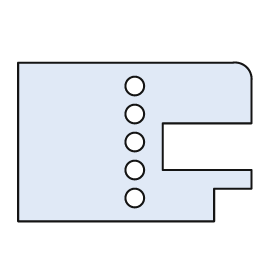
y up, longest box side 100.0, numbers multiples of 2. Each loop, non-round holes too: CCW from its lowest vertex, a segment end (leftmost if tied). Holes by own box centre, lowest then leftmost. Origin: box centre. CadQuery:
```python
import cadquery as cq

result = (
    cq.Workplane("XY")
    .moveTo(-50.0, -34.0)
    .lineTo(34.0, -34.0)
    .lineTo(34.0, -20.0)
    .lineTo(50.0, -20.0)
    .lineTo(50.0, -12.0)
    .lineTo(12.0, -12.0)
    .lineTo(12.0, 8.0)
    .lineTo(50.0, 8.0)
    .lineTo(50.0, 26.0)
    .threePointArc((48.0, 32.0), (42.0, 34.0))
    .lineTo(-50.0, 34.0)
    .close()
    .moveTo(0.0, -24.0)
    .circle(4.0)
    .moveTo(0.0, -12.0)
    .circle(4.0)
    .moveTo(0.0, 0.0)
    .circle(4.0)
    .moveTo(0.0, 12.0)
    .circle(4.0)
    .moveTo(0.0, 24.0)
    .circle(4.0)
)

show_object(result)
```